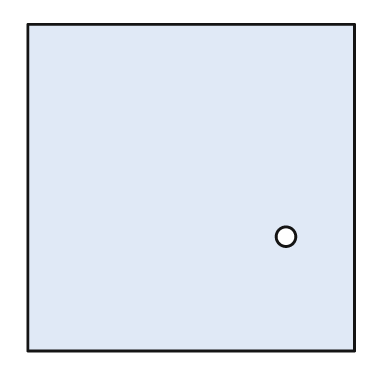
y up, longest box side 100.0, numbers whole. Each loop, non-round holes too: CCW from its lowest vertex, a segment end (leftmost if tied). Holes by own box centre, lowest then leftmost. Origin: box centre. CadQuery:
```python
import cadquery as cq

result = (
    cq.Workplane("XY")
    .moveTo(-50.0, -50.0)
    .lineTo(50.0, -50.0)
    .lineTo(50.0, 50.0)
    .lineTo(-50.0, 50.0)
    .close()
    .moveTo(29.0, -15.0)
    .circle(3.0)
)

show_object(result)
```